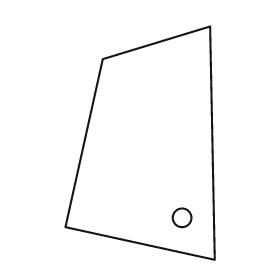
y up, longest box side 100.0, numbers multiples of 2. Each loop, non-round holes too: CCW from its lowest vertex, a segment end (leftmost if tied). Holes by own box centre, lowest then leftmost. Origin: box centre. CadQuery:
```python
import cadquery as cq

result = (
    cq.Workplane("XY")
    .moveTo(32.0, -50.0)
    .lineTo(30.0, 50.0)
    .lineTo(-16.0, 36.0)
    .lineTo(-32.0, -36.0)
    .close()
    .moveTo(18.0, -32.0)
    .circle(4.0)
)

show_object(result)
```